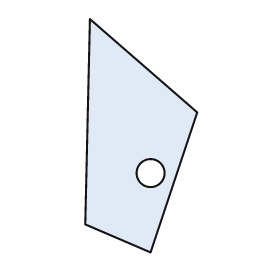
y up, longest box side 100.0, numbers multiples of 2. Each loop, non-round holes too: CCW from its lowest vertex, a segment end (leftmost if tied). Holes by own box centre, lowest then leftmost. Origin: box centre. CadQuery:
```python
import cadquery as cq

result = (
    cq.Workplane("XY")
    .moveTo(4.0, -50.0)
    .lineTo(24.0, 10.0)
    .lineTo(-22.0, 50.0)
    .lineTo(-24.0, -38.0)
    .close()
    .moveTo(4.0, -16.0)
    .circle(6.0)
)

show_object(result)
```